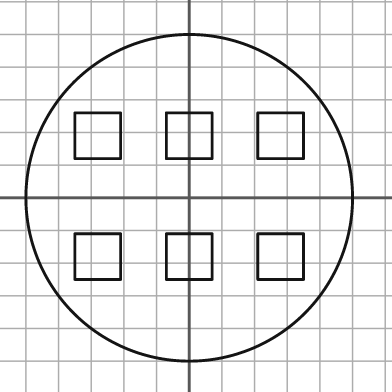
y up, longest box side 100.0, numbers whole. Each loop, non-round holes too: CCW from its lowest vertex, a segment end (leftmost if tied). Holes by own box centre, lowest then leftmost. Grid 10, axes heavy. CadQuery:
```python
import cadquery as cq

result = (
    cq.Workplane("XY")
    .moveTo(0.0, 0.0)
    .circle(50.0)
    .moveTo(-35.0, -25.0)
    .lineTo(-21.0, -25.0)
    .lineTo(-21.0, -11.0)
    .lineTo(-35.0, -11.0)
    .close()
    .moveTo(-7.0, -25.0)
    .lineTo(7.0, -25.0)
    .lineTo(7.0, -11.0)
    .lineTo(-7.0, -11.0)
    .close()
    .moveTo(21.0, -25.0)
    .lineTo(35.0, -25.0)
    .lineTo(35.0, -11.0)
    .lineTo(21.0, -11.0)
    .close()
    .moveTo(-35.0, 12.0)
    .lineTo(-21.0, 12.0)
    .lineTo(-21.0, 26.0)
    .lineTo(-35.0, 26.0)
    .close()
    .moveTo(-7.0, 12.0)
    .lineTo(7.0, 12.0)
    .lineTo(7.0, 26.0)
    .lineTo(-7.0, 26.0)
    .close()
    .moveTo(21.0, 12.0)
    .lineTo(35.0, 12.0)
    .lineTo(35.0, 26.0)
    .lineTo(21.0, 26.0)
    .close()
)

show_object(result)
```